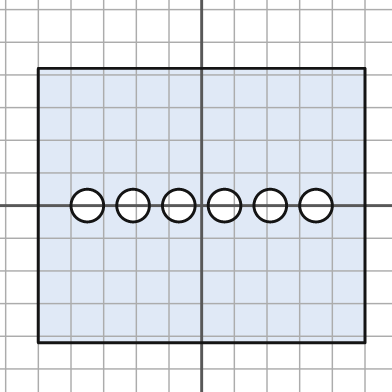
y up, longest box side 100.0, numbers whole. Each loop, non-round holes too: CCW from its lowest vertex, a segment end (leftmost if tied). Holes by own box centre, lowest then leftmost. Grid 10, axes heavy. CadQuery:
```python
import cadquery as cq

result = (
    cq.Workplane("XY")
    .moveTo(-50.0, -42.0)
    .lineTo(50.0, -42.0)
    .lineTo(50.0, 42.0)
    .lineTo(-50.0, 42.0)
    .close()
    .moveTo(-35.0, 0.0)
    .circle(5.0)
    .moveTo(-21.0, 0.0)
    .circle(5.0)
    .moveTo(-7.0, 0.0)
    .circle(5.0)
    .moveTo(7.0, 0.0)
    .circle(5.0)
    .moveTo(21.0, 0.0)
    .circle(5.0)
    .moveTo(35.0, 0.0)
    .circle(5.0)
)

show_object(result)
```